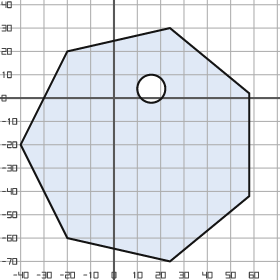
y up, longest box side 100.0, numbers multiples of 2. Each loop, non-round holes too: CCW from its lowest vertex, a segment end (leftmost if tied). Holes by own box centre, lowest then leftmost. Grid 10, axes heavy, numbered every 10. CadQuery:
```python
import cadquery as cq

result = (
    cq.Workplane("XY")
    .moveTo(24.0, -70.0)
    .lineTo(58.0, -42.0)
    .lineTo(58.0, 2.0)
    .lineTo(24.0, 30.0)
    .lineTo(-20.0, 20.0)
    .lineTo(-40.0, -20.0)
    .lineTo(-20.0, -60.0)
    .close()
    .moveTo(16.0, 4.0)
    .circle(6.0)
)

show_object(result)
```